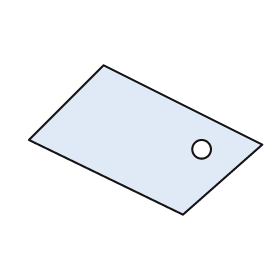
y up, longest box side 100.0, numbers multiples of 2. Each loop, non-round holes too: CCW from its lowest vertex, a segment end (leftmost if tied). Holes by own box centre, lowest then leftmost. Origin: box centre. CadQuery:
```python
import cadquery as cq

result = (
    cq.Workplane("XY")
    .moveTo(16.0, -32.0)
    .lineTo(50.0, -2.0)
    .lineTo(-18.0, 32.0)
    .lineTo(-50.0, 0.0)
    .close()
    .moveTo(24.0, -4.0)
    .circle(4.0)
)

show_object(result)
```